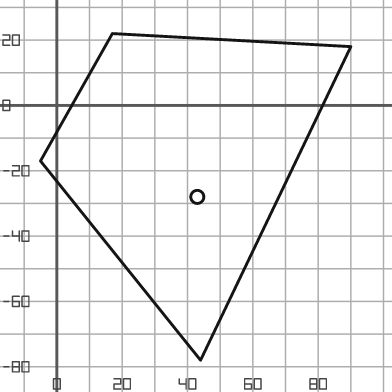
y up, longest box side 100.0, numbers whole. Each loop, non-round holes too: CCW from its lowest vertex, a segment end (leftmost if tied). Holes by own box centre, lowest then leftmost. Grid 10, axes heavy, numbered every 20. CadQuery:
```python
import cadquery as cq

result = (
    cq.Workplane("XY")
    .moveTo(44.0, -78.0)
    .lineTo(90.0, 18.0)
    .lineTo(17.0, 22.0)
    .lineTo(-5.0, -17.0)
    .close()
    .moveTo(43.0, -28.0)
    .circle(2.0)
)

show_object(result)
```